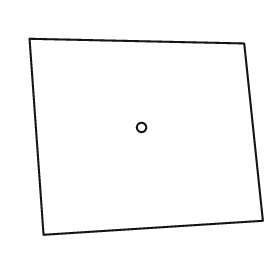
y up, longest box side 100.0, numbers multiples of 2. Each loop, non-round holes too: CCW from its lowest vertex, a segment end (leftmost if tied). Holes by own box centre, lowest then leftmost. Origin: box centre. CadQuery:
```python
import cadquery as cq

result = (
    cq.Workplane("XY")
    .moveTo(-44.0, -42.0)
    .lineTo(50.0, -36.0)
    .lineTo(42.0, 40.0)
    .lineTo(-50.0, 42.0)
    .close()
    .moveTo(-2.0, 4.0)
    .circle(2.0)
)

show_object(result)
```